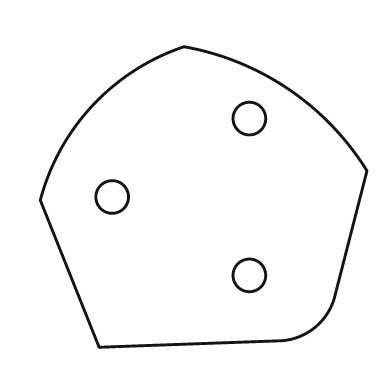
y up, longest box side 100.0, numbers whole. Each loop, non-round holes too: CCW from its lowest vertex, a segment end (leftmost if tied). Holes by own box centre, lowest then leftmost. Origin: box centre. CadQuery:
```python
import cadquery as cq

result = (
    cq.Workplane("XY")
    .moveTo(-32.0, -46.0)
    .lineTo(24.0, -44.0)
    .threePointArc((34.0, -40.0), (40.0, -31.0))
    .lineTo(50.0, 8.0)
    .threePointArc((26.0, 33.0), (-6.0, 46.0))
    .threePointArc((-34.0, 28.0), (-50.0, -1.0))
    .close()
    .moveTo(14.0, -24.0)
    .circle(5.0)
    .moveTo(-28.0, 0.0)
    .circle(5.0)
    .moveTo(14.0, 24.0)
    .circle(5.0)
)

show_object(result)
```